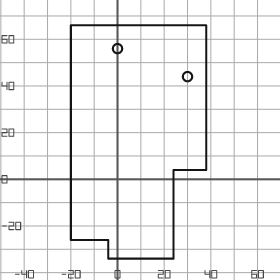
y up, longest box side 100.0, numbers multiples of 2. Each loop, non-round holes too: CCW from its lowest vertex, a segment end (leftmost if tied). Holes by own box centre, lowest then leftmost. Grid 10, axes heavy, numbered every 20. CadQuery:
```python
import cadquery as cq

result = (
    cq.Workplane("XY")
    .moveTo(-4.0, -34.0)
    .lineTo(24.0, -34.0)
    .lineTo(24.0, 4.0)
    .lineTo(38.0, 4.0)
    .lineTo(38.0, 66.0)
    .lineTo(-20.0, 66.0)
    .lineTo(-20.0, -26.0)
    .lineTo(-4.0, -26.0)
    .close()
    .moveTo(30.0, 44.0)
    .circle(2.0)
    .moveTo(0.0, 56.0)
    .circle(2.0)
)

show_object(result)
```